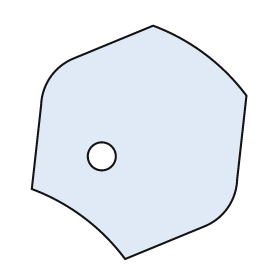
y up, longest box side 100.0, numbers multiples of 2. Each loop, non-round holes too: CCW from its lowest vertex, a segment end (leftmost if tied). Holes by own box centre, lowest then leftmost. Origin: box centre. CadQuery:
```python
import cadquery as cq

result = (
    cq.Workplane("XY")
    .moveTo(-6.0, -50.0)
    .lineTo(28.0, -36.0)
    .threePointArc((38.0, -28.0), (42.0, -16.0))
    .lineTo(46.0, 20.0)
    .threePointArc((28.0, 38.0), (6.0, 50.0))
    .lineTo(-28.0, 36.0)
    .threePointArc((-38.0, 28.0), (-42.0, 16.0))
    .lineTo(-46.0, -20.0)
    .threePointArc((-24.0, -32.0), (-6.0, -50.0))
    .close()
    .moveTo(-16.0, -6.0)
    .circle(6.0)
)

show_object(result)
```